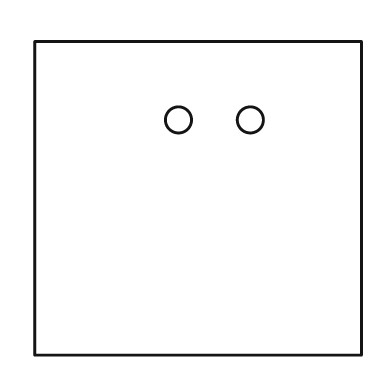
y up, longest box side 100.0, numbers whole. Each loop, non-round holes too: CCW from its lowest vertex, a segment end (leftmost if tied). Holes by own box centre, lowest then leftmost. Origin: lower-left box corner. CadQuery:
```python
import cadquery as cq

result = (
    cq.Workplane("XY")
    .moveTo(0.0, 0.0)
    .lineTo(100.0, 0.0)
    .lineTo(100.0, 96.0)
    .lineTo(0.0, 96.0)
    .close()
    .moveTo(44.0, 72.0)
    .circle(4.0)
    .moveTo(66.0, 72.0)
    .circle(4.0)
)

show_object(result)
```